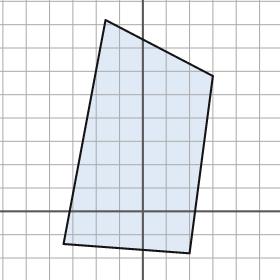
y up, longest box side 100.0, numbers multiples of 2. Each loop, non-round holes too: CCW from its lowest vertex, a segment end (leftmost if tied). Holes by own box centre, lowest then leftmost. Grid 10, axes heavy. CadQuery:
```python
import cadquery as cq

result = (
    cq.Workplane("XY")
    .moveTo(20.0, -18.0)
    .lineTo(30.0, 58.0)
    .lineTo(-16.0, 82.0)
    .lineTo(-34.0, -14.0)
    .close()
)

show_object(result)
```